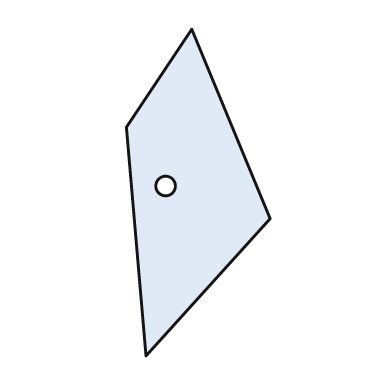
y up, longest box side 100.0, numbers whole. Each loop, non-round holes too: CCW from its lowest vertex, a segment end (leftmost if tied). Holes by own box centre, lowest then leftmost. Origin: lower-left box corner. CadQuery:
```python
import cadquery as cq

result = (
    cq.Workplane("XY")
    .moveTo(6.0, 0.0)
    .lineTo(44.0, 42.0)
    .lineTo(20.0, 100.0)
    .lineTo(0.0, 70.0)
    .close()
    .moveTo(12.0, 52.0)
    .circle(3.0)
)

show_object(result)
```